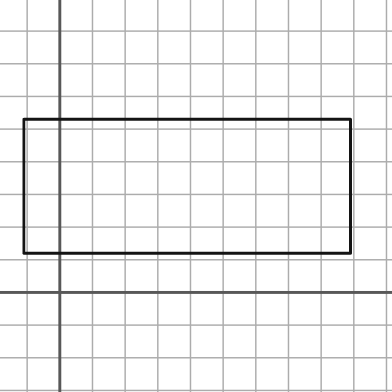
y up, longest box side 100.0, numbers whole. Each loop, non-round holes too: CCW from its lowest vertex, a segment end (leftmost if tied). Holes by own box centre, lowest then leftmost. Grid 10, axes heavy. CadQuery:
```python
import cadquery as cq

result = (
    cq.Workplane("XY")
    .moveTo(-11.0, 12.0)
    .lineTo(89.0, 12.0)
    .lineTo(89.0, 53.0)
    .lineTo(-11.0, 53.0)
    .close()
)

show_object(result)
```